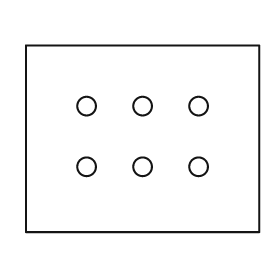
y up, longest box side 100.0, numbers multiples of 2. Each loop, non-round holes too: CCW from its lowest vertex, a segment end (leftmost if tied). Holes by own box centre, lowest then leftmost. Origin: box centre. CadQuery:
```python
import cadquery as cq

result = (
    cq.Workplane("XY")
    .moveTo(-50.0, -40.0)
    .lineTo(50.0, -40.0)
    .lineTo(50.0, 40.0)
    .lineTo(-50.0, 40.0)
    .close()
    .moveTo(-24.0, -12.0)
    .circle(4.0)
    .moveTo(0.0, -12.0)
    .circle(4.0)
    .moveTo(24.0, -12.0)
    .circle(4.0)
    .moveTo(-24.0, 14.0)
    .circle(4.0)
    .moveTo(0.0, 14.0)
    .circle(4.0)
    .moveTo(24.0, 14.0)
    .circle(4.0)
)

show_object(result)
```